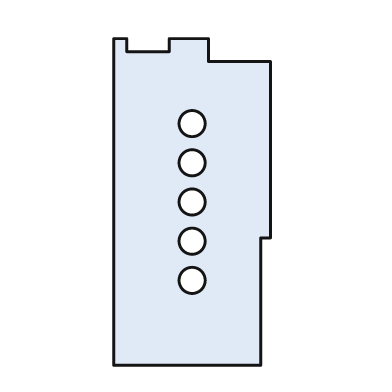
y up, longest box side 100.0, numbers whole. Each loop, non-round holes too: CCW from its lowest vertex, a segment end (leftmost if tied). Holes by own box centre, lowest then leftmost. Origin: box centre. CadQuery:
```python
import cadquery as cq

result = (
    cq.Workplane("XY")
    .moveTo(-24.0, -50.0)
    .lineTo(21.0, -50.0)
    .lineTo(21.0, -11.0)
    .lineTo(24.0, -11.0)
    .lineTo(24.0, 43.0)
    .lineTo(5.0, 43.0)
    .lineTo(5.0, 50.0)
    .lineTo(-7.0, 50.0)
    .lineTo(-7.0, 46.0)
    .lineTo(-20.0, 46.0)
    .lineTo(-20.0, 50.0)
    .lineTo(-24.0, 50.0)
    .close()
    .moveTo(0.0, -24.0)
    .circle(4.0)
    .moveTo(0.0, -12.0)
    .circle(4.0)
    .moveTo(0.0, 0.0)
    .circle(4.0)
    .moveTo(0.0, 12.0)
    .circle(4.0)
    .moveTo(0.0, 24.0)
    .circle(4.0)
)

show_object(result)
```